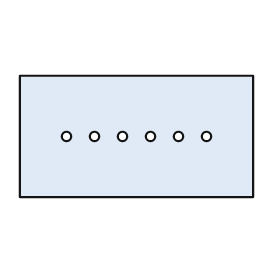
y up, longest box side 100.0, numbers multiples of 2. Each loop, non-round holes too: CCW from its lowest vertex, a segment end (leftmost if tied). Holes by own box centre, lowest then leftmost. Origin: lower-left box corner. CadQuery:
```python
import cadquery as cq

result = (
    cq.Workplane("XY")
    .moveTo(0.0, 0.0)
    .lineTo(100.0, 0.0)
    .lineTo(100.0, 52.0)
    .lineTo(0.0, 52.0)
    .close()
    .moveTo(20.0, 26.0)
    .circle(2.0)
    .moveTo(32.0, 26.0)
    .circle(2.0)
    .moveTo(44.0, 26.0)
    .circle(2.0)
    .moveTo(56.0, 26.0)
    .circle(2.0)
    .moveTo(68.0, 26.0)
    .circle(2.0)
    .moveTo(80.0, 26.0)
    .circle(2.0)
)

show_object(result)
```